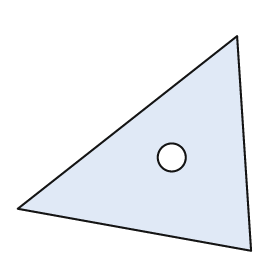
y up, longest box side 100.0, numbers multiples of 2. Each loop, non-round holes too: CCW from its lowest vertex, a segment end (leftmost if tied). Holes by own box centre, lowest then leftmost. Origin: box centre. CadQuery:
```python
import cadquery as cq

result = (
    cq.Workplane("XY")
    .moveTo(50.0, -46.0)
    .lineTo(44.0, 46.0)
    .lineTo(-50.0, -28.0)
    .close()
    .moveTo(16.0, -6.0)
    .circle(6.0)
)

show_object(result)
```